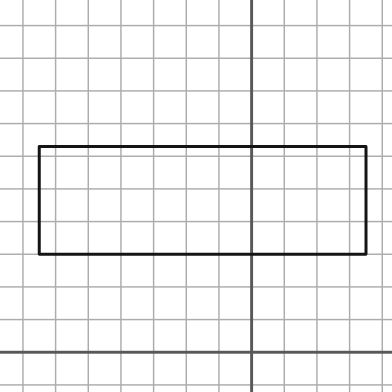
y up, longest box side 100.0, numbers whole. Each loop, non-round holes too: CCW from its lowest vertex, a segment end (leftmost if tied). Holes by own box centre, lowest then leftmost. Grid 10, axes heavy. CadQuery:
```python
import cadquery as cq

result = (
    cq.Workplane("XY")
    .moveTo(-65.0, 30.0)
    .lineTo(35.0, 30.0)
    .lineTo(35.0, 63.0)
    .lineTo(-65.0, 63.0)
    .close()
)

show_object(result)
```